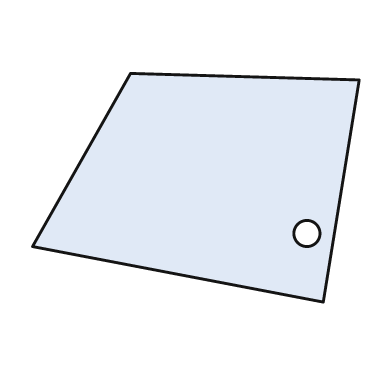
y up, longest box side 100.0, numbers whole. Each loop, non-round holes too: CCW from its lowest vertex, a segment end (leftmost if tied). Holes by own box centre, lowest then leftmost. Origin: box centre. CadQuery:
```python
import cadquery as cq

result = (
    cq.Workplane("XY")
    .moveTo(39.0, -35.0)
    .lineTo(50.0, 33.0)
    .lineTo(-20.0, 35.0)
    .lineTo(-50.0, -18.0)
    .close()
    .moveTo(34.0, -14.0)
    .circle(4.0)
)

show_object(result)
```